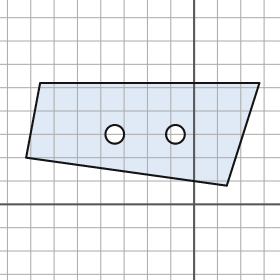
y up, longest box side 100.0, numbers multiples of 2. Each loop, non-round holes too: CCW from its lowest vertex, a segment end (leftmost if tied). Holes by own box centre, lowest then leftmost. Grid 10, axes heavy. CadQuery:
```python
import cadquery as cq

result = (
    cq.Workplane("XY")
    .moveTo(14.0, 8.0)
    .lineTo(28.0, 52.0)
    .lineTo(-66.0, 52.0)
    .lineTo(-72.0, 20.0)
    .close()
    .moveTo(-34.0, 30.0)
    .circle(4.0)
    .moveTo(-8.0, 30.0)
    .circle(4.0)
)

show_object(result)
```